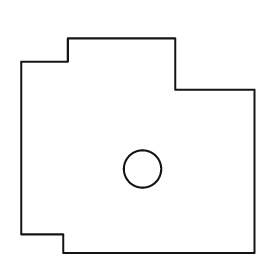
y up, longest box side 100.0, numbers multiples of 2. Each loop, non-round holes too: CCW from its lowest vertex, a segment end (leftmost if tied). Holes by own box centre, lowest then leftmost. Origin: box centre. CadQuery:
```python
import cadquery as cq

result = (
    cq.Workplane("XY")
    .moveTo(-32.0, -46.0)
    .lineTo(50.0, -46.0)
    .lineTo(50.0, 24.0)
    .lineTo(16.0, 24.0)
    .lineTo(16.0, 46.0)
    .lineTo(-30.0, 46.0)
    .lineTo(-30.0, 36.0)
    .lineTo(-50.0, 36.0)
    .lineTo(-50.0, -38.0)
    .lineTo(-32.0, -38.0)
    .close()
    .moveTo(2.0, -10.0)
    .circle(8.0)
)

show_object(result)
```